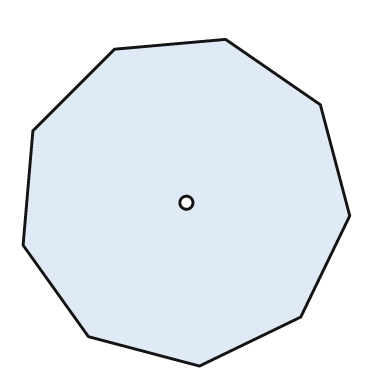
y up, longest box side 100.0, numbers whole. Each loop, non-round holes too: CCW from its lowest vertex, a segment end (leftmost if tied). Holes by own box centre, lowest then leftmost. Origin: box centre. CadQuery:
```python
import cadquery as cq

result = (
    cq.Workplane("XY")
    .moveTo(4.0, -50.0)
    .lineTo(35.0, -35.0)
    .lineTo(50.0, -4.0)
    .lineTo(41.0, 30.0)
    .lineTo(12.0, 50.0)
    .lineTo(-22.0, 47.0)
    .lineTo(-47.0, 22.0)
    .lineTo(-50.0, -13.0)
    .lineTo(-30.0, -41.0)
    .close()
    .moveTo(0.0, 0.0)
    .circle(2.0)
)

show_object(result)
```